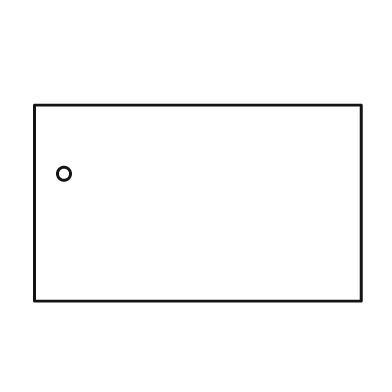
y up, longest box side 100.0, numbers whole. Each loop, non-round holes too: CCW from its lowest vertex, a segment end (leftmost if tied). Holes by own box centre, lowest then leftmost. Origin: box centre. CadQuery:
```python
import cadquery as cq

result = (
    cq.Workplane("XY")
    .moveTo(-50.0, -30.0)
    .lineTo(50.0, -30.0)
    .lineTo(50.0, 30.0)
    .lineTo(-50.0, 30.0)
    .close()
    .moveTo(-41.0, 9.0)
    .circle(2.0)
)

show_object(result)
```